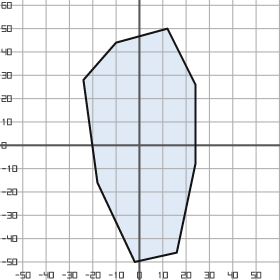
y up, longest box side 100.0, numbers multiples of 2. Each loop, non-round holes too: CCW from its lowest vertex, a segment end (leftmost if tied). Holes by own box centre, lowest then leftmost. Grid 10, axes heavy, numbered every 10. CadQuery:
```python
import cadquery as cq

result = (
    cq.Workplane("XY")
    .moveTo(-2.0, -50.0)
    .lineTo(16.0, -46.0)
    .lineTo(24.0, -8.0)
    .lineTo(24.0, 26.0)
    .lineTo(12.0, 50.0)
    .lineTo(-10.0, 44.0)
    .lineTo(-24.0, 28.0)
    .lineTo(-18.0, -16.0)
    .close()
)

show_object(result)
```